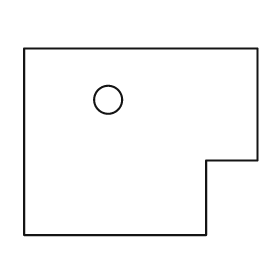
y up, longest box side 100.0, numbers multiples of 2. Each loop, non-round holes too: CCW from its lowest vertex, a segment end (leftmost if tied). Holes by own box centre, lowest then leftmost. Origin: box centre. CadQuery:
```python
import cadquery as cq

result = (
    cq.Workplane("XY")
    .moveTo(-50.0, -40.0)
    .lineTo(28.0, -40.0)
    .lineTo(28.0, -8.0)
    .lineTo(50.0, -8.0)
    .lineTo(50.0, 40.0)
    .lineTo(-50.0, 40.0)
    .close()
    .moveTo(-14.0, 18.0)
    .circle(6.0)
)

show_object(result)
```